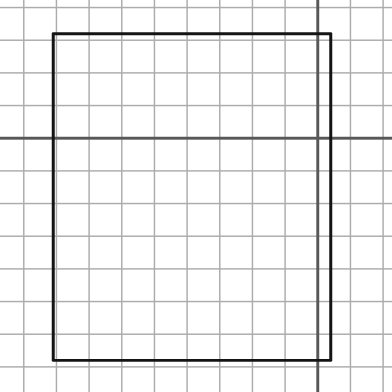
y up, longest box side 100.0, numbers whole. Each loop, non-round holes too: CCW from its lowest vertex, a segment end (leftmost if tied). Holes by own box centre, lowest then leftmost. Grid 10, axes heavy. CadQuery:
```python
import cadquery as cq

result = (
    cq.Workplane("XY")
    .moveTo(-81.0, -68.0)
    .lineTo(4.0, -68.0)
    .lineTo(4.0, 32.0)
    .lineTo(-81.0, 32.0)
    .close()
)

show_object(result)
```